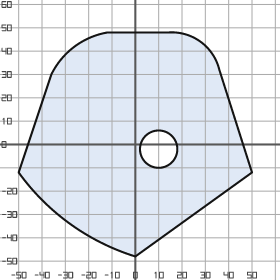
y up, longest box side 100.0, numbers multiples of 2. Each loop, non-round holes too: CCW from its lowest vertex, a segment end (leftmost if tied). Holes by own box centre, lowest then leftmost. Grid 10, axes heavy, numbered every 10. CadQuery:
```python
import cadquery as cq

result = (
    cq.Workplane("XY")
    .moveTo(0.0, -48.0)
    .lineTo(50.0, -12.0)
    .lineTo(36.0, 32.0)
    .threePointArc((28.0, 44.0), (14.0, 48.0))
    .lineTo(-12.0, 48.0)
    .threePointArc((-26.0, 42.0), (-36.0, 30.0))
    .lineTo(-50.0, -12.0)
    .threePointArc((-28.0, -34.0), (0.0, -48.0))
    .close()
    .moveTo(10.0, -2.0)
    .circle(8.0)
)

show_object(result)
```